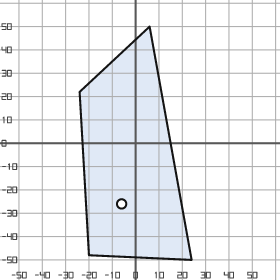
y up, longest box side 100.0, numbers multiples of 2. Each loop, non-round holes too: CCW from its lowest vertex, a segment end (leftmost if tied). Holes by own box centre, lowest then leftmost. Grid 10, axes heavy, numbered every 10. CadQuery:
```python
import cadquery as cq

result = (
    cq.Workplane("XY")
    .moveTo(24.0, -50.0)
    .lineTo(6.0, 50.0)
    .lineTo(-24.0, 22.0)
    .lineTo(-20.0, -48.0)
    .close()
    .moveTo(-6.0, -26.0)
    .circle(2.0)
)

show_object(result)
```